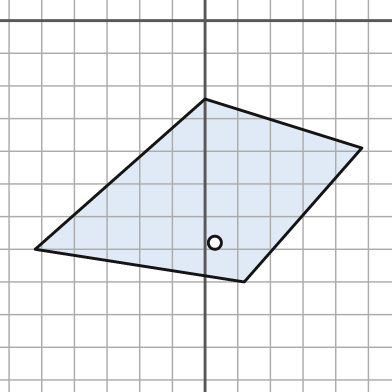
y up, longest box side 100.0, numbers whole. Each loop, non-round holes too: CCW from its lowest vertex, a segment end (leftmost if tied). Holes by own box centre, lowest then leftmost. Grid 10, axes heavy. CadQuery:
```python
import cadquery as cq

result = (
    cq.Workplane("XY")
    .moveTo(12.0, -80.0)
    .lineTo(48.0, -39.0)
    .lineTo(0.0, -24.0)
    .lineTo(-52.0, -70.0)
    .close()
    .moveTo(3.0, -68.0)
    .circle(2.0)
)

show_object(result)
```